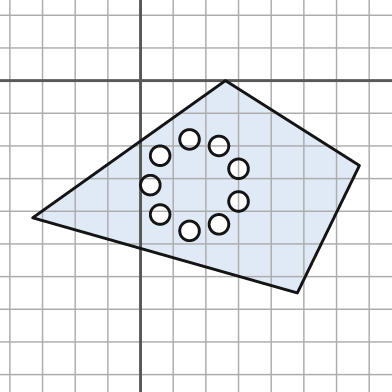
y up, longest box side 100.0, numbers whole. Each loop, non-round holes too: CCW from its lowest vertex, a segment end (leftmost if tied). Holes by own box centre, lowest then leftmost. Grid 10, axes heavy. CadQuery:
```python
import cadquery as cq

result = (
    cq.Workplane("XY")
    .moveTo(48.0, -65.0)
    .lineTo(67.0, -26.0)
    .lineTo(26.0, 0.0)
    .lineTo(-33.0, -42.0)
    .close()
    .moveTo(15.0, -46.0)
    .circle(3.0)
    .moveTo(24.0, -44.0)
    .circle(3.0)
    .moveTo(6.0, -41.0)
    .circle(3.0)
    .moveTo(30.0, -37.0)
    .circle(3.0)
    .moveTo(3.0, -32.0)
    .circle(3.0)
    .moveTo(30.0, -27.0)
    .circle(3.0)
    .moveTo(6.0, -23.0)
    .circle(3.0)
    .moveTo(24.0, -20.0)
    .circle(3.0)
    .moveTo(15.0, -18.0)
    .circle(3.0)
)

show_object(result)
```